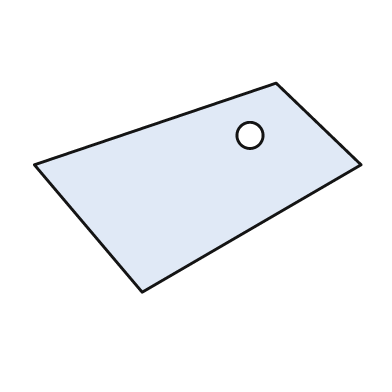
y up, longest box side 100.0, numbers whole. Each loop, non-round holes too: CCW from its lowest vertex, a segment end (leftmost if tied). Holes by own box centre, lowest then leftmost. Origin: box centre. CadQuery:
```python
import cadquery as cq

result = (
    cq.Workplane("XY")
    .moveTo(-17.0, -32.0)
    .lineTo(50.0, 7.0)
    .lineTo(24.0, 32.0)
    .lineTo(-50.0, 7.0)
    .close()
    .moveTo(16.0, 16.0)
    .circle(4.0)
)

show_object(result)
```